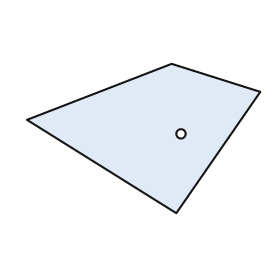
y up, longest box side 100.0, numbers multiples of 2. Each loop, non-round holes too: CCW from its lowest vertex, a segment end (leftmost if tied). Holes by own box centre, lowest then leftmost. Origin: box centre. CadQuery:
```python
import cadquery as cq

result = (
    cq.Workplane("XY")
    .moveTo(14.0, -32.0)
    .lineTo(50.0, 20.0)
    .lineTo(12.0, 32.0)
    .lineTo(-50.0, 8.0)
    .close()
    .moveTo(16.0, 2.0)
    .circle(2.0)
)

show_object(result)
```